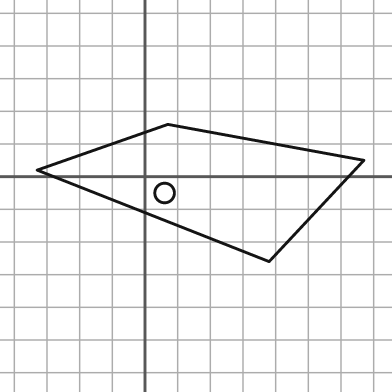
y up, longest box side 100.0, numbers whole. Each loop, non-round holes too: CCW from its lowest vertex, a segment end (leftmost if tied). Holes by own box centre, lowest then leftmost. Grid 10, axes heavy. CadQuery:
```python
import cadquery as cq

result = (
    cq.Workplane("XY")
    .moveTo(38.0, -26.0)
    .lineTo(67.0, 5.0)
    .lineTo(7.0, 16.0)
    .lineTo(-33.0, 2.0)
    .close()
    .moveTo(6.0, -5.0)
    .circle(3.0)
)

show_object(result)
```